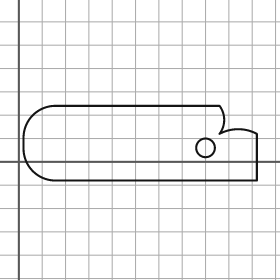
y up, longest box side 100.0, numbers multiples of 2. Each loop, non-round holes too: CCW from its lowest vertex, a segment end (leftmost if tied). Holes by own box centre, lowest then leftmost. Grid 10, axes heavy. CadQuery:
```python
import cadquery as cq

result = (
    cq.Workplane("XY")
    .moveTo(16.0, -8.0)
    .lineTo(102.0, -8.0)
    .lineTo(102.0, 12.0)
    .threePointArc((94.0, 14.0), (86.0, 12.0))
    .threePointArc((88.0, 18.0), (86.0, 24.0))
    .lineTo(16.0, 24.0)
    .threePointArc((6.0, 20.0), (2.0, 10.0))
    .lineTo(2.0, 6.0)
    .threePointArc((6.0, -4.0), (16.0, -8.0))
    .close()
    .moveTo(80.0, 6.0)
    .circle(4.0)
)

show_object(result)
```